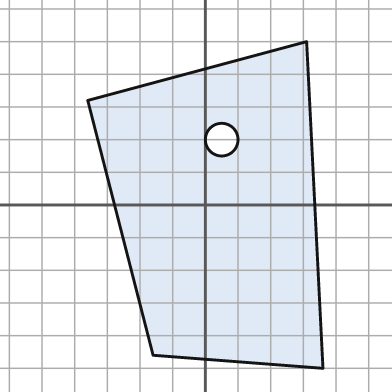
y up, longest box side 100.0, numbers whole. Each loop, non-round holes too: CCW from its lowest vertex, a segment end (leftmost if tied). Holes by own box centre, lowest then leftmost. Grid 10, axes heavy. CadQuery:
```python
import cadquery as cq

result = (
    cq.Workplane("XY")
    .moveTo(36.0, -50.0)
    .lineTo(31.0, 50.0)
    .lineTo(-36.0, 32.0)
    .lineTo(-16.0, -46.0)
    .close()
    .moveTo(5.0, 20.0)
    .circle(5.0)
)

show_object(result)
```